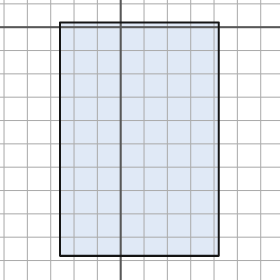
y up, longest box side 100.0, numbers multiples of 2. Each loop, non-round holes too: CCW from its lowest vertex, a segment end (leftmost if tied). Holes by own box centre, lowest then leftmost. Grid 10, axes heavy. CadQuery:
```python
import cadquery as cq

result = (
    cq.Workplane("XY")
    .moveTo(-26.0, -98.0)
    .lineTo(42.0, -98.0)
    .lineTo(42.0, 2.0)
    .lineTo(-26.0, 2.0)
    .close()
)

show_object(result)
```